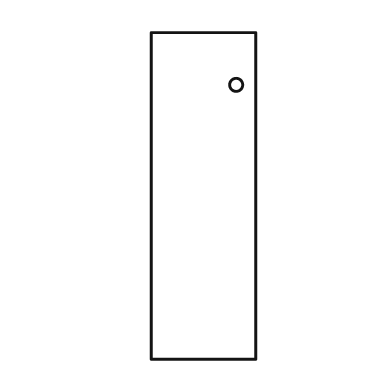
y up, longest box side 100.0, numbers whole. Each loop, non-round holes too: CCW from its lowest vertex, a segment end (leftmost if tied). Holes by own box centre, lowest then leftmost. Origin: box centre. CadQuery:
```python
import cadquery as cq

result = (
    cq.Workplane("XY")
    .moveTo(-16.0, -50.0)
    .lineTo(16.0, -50.0)
    .lineTo(16.0, 50.0)
    .lineTo(-16.0, 50.0)
    .close()
    .moveTo(10.0, 34.0)
    .circle(2.0)
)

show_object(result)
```